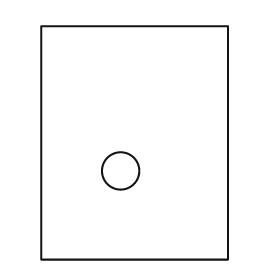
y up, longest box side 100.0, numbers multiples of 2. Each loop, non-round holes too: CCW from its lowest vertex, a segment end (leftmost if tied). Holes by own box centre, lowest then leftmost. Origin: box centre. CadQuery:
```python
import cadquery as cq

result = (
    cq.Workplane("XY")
    .moveTo(-40.0, -50.0)
    .lineTo(40.0, -50.0)
    .lineTo(40.0, 50.0)
    .lineTo(-40.0, 50.0)
    .close()
    .moveTo(-6.0, -12.0)
    .circle(8.0)
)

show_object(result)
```